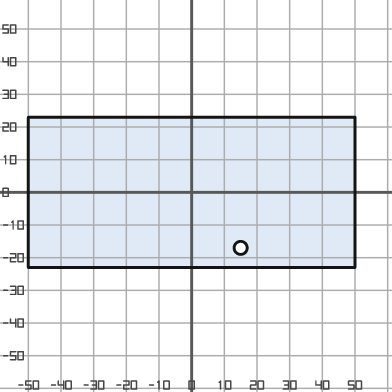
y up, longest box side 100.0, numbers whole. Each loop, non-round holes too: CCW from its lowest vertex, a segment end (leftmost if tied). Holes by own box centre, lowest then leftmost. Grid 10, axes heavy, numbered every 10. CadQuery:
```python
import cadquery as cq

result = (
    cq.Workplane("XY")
    .moveTo(-50.0, -23.0)
    .lineTo(50.0, -23.0)
    .lineTo(50.0, 23.0)
    .lineTo(-50.0, 23.0)
    .close()
    .moveTo(15.0, -17.0)
    .circle(2.0)
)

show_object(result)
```